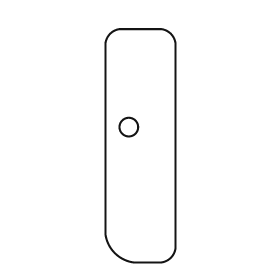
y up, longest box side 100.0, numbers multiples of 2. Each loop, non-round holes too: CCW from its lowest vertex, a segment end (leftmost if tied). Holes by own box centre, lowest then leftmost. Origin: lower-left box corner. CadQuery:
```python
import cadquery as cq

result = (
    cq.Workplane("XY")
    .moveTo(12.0, 0.0)
    .lineTo(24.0, 0.0)
    .threePointArc((28.0, 2.0), (30.0, 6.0))
    .lineTo(30.0, 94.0)
    .threePointArc((28.0, 98.0), (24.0, 100.0))
    .lineTo(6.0, 100.0)
    .threePointArc((2.0, 98.0), (0.0, 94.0))
    .lineTo(0.0, 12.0)
    .threePointArc((4.0, 4.0), (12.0, 0.0))
    .close()
    .moveTo(10.0, 58.0)
    .circle(4.0)
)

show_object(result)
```